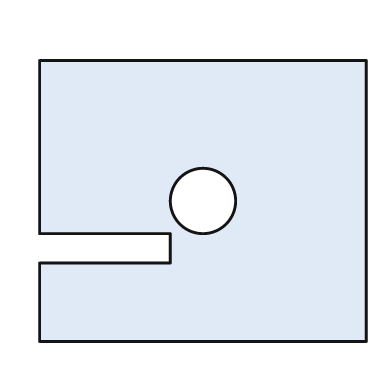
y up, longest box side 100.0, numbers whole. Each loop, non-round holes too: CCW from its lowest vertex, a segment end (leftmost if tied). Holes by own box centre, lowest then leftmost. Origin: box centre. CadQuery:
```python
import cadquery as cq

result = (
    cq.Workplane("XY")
    .moveTo(-50.0, -43.0)
    .lineTo(50.0, -43.0)
    .lineTo(50.0, 43.0)
    .lineTo(-50.0, 43.0)
    .lineTo(-50.0, -10.0)
    .lineTo(-10.0, -10.0)
    .lineTo(-10.0, -19.0)
    .lineTo(-50.0, -19.0)
    .close()
    .moveTo(0.0, 0.0)
    .circle(10.0)
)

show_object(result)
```